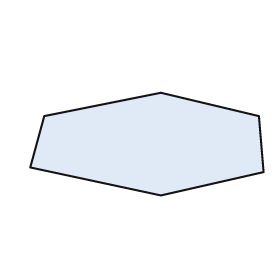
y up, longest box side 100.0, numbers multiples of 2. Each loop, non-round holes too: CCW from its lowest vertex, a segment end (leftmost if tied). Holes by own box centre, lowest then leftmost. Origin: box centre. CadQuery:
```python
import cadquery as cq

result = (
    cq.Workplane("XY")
    .moveTo(6.0, -22.0)
    .lineTo(50.0, -12.0)
    .lineTo(48.0, 12.0)
    .lineTo(6.0, 22.0)
    .lineTo(-44.0, 12.0)
    .lineTo(-50.0, -10.0)
    .close()
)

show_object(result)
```